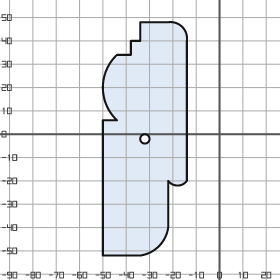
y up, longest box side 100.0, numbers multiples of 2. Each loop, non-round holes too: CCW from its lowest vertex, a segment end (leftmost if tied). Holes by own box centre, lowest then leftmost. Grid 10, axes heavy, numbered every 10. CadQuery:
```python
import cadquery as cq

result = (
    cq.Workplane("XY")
    .moveTo(-50.0, -52.0)
    .lineTo(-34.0, -52.0)
    .threePointArc((-26.0, -48.0), (-22.0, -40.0))
    .lineTo(-22.0, -20.0)
    .threePointArc((-18.0, -22.0), (-14.0, -20.0))
    .lineTo(-14.0, 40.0)
    .threePointArc((-16.0, 46.0), (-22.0, 48.0))
    .lineTo(-34.0, 48.0)
    .lineTo(-34.0, 40.0)
    .lineTo(-38.0, 40.0)
    .lineTo(-38.0, 34.0)
    .lineTo(-44.0, 34.0)
    .threePointArc((-50.0, 20.0), (-44.0, 6.0))
    .lineTo(-50.0, 6.0)
    .close()
    .moveTo(-32.0, -2.0)
    .circle(2.0)
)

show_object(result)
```